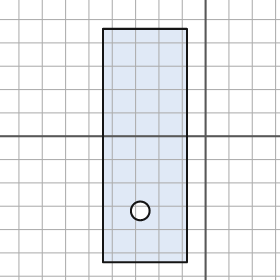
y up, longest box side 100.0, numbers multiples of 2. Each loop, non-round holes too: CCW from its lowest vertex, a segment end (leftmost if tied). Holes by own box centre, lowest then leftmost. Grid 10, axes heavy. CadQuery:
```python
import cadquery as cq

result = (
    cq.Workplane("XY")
    .moveTo(-44.0, -54.0)
    .lineTo(-8.0, -54.0)
    .lineTo(-8.0, 46.0)
    .lineTo(-44.0, 46.0)
    .close()
    .moveTo(-28.0, -32.0)
    .circle(4.0)
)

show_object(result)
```